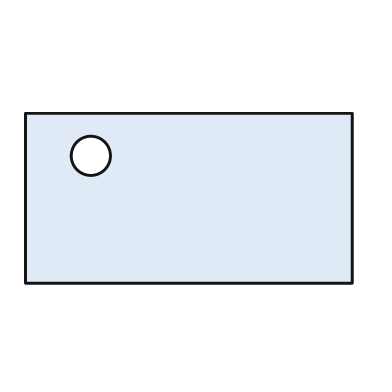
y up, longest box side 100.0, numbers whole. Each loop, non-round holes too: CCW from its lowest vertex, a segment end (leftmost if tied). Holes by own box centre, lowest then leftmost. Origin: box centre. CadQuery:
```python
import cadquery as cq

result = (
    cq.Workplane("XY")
    .moveTo(-50.0, -26.0)
    .lineTo(50.0, -26.0)
    .lineTo(50.0, 26.0)
    .lineTo(-50.0, 26.0)
    .close()
    .moveTo(-30.0, 13.0)
    .circle(6.0)
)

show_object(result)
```